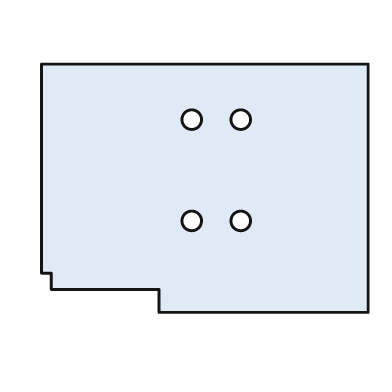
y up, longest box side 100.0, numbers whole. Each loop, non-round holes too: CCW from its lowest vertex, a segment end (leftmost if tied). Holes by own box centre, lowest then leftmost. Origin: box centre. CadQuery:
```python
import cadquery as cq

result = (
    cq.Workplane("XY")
    .moveTo(-14.0, -38.0)
    .lineTo(50.0, -38.0)
    .lineTo(50.0, 38.0)
    .lineTo(-50.0, 38.0)
    .lineTo(-50.0, -26.0)
    .lineTo(-47.0, -26.0)
    .lineTo(-47.0, -31.0)
    .lineTo(-14.0, -31.0)
    .close()
    .moveTo(-4.0, -10.0)
    .circle(3.0)
    .moveTo(11.0, -10.0)
    .circle(3.0)
    .moveTo(-4.0, 21.0)
    .circle(3.0)
    .moveTo(11.0, 21.0)
    .circle(3.0)
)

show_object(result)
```